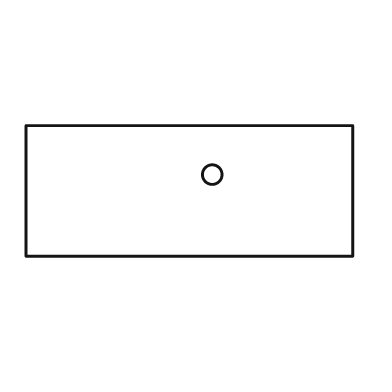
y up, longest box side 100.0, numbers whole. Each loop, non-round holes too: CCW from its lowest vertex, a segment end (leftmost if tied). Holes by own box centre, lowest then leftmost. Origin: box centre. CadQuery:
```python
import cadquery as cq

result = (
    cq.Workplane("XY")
    .moveTo(-50.0, -20.0)
    .lineTo(50.0, -20.0)
    .lineTo(50.0, 20.0)
    .lineTo(-50.0, 20.0)
    .close()
    .moveTo(7.0, 5.0)
    .circle(3.0)
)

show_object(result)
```